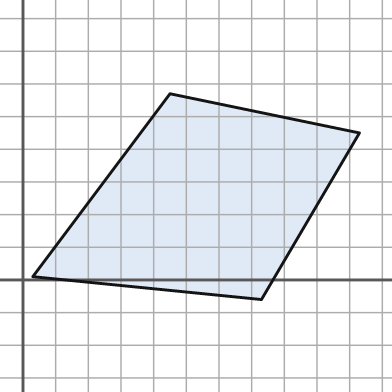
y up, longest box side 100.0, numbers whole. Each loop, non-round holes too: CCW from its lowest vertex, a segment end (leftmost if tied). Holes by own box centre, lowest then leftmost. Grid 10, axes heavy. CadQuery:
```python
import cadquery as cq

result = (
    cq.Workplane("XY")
    .moveTo(73.0, -6.0)
    .lineTo(103.0, 45.0)
    .lineTo(45.0, 57.0)
    .lineTo(3.0, 1.0)
    .close()
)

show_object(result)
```